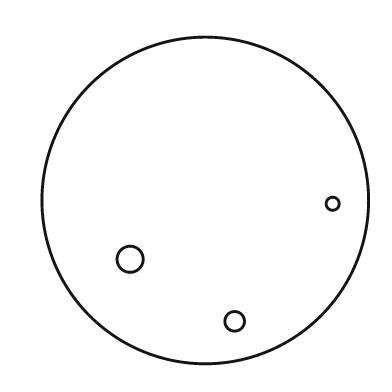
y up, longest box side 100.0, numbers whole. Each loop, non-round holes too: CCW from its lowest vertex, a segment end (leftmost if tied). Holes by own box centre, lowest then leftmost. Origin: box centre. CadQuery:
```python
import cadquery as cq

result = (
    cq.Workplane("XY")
    .moveTo(0.0, 0.0)
    .circle(50.0)
    .moveTo(9.0, -37.0)
    .circle(3.0)
    .moveTo(-23.0, -18.0)
    .circle(4.0)
    .moveTo(39.0, -1.0)
    .circle(2.0)
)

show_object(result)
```